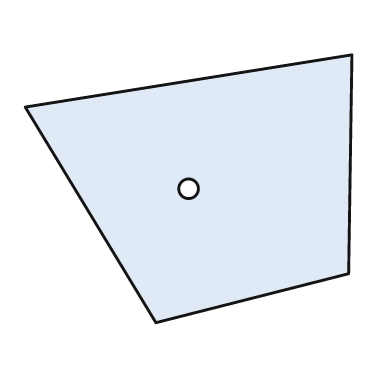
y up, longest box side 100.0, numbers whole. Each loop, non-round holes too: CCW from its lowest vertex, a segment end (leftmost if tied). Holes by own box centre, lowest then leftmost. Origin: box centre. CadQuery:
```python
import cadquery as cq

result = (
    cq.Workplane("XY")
    .moveTo(-10.0, -41.0)
    .lineTo(49.0, -26.0)
    .lineTo(50.0, 41.0)
    .lineTo(-50.0, 25.0)
    .close()
    .moveTo(0.0, 0.0)
    .circle(3.0)
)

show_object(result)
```